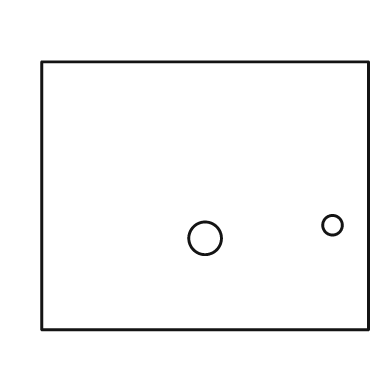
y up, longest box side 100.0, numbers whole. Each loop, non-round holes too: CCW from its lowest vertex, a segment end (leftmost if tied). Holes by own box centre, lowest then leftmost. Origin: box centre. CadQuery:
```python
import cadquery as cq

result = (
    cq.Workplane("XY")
    .moveTo(-50.0, -41.0)
    .lineTo(50.0, -41.0)
    .lineTo(50.0, 41.0)
    .lineTo(-50.0, 41.0)
    .close()
    .moveTo(0.0, -13.0)
    .circle(5.0)
    .moveTo(39.0, -9.0)
    .circle(3.0)
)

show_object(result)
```